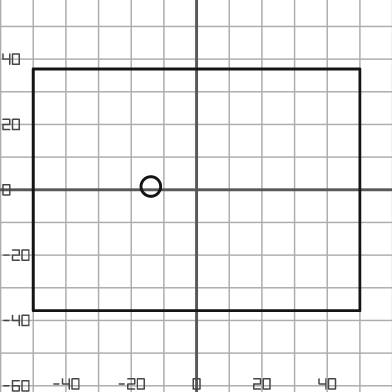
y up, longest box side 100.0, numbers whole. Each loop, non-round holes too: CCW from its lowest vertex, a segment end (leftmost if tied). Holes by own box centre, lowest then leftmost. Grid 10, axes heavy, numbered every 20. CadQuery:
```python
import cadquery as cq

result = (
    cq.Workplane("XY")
    .moveTo(-50.0, -37.0)
    .lineTo(50.0, -37.0)
    .lineTo(50.0, 37.0)
    .lineTo(-50.0, 37.0)
    .close()
    .moveTo(-14.0, 1.0)
    .circle(3.0)
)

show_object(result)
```